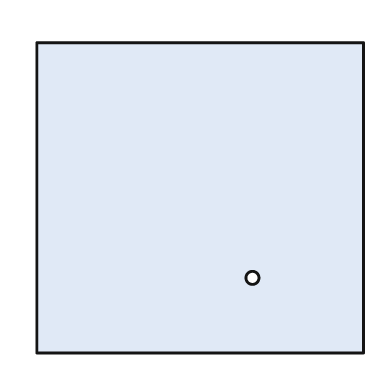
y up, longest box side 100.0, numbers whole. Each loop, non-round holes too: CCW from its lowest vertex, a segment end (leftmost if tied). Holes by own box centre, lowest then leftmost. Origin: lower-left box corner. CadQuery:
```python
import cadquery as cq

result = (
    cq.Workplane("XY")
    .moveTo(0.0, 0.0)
    .lineTo(100.0, 0.0)
    .lineTo(100.0, 95.0)
    .lineTo(0.0, 95.0)
    .close()
    .moveTo(66.0, 23.0)
    .circle(2.0)
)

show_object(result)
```